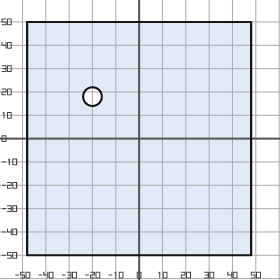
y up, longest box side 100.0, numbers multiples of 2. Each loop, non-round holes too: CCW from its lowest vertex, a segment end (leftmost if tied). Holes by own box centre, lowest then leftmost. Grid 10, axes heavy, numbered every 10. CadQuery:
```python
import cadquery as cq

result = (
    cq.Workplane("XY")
    .moveTo(-48.0, -50.0)
    .lineTo(48.0, -50.0)
    .lineTo(48.0, 50.0)
    .lineTo(-48.0, 50.0)
    .close()
    .moveTo(-20.0, 18.0)
    .circle(4.0)
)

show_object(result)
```